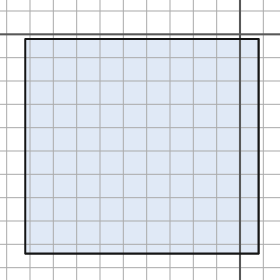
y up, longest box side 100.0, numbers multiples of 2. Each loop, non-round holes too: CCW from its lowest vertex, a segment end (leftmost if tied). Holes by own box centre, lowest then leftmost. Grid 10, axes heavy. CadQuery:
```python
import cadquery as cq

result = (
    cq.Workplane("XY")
    .moveTo(-92.0, -94.0)
    .lineTo(8.0, -94.0)
    .lineTo(8.0, -2.0)
    .lineTo(-92.0, -2.0)
    .close()
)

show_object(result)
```